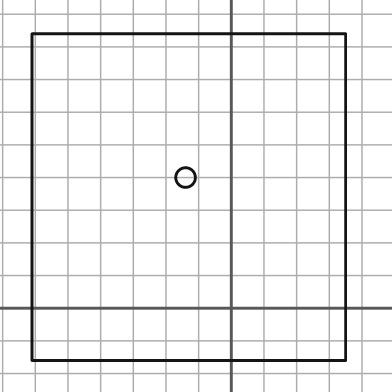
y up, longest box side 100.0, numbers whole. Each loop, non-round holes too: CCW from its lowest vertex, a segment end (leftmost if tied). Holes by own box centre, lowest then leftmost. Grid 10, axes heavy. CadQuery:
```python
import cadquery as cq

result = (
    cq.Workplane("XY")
    .moveTo(-61.0, -16.0)
    .lineTo(35.0, -16.0)
    .lineTo(35.0, 84.0)
    .lineTo(-61.0, 84.0)
    .close()
    .moveTo(-14.0, 40.0)
    .circle(3.0)
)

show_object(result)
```